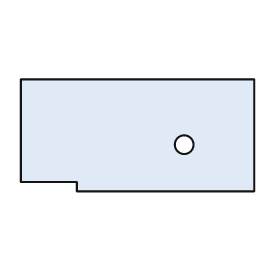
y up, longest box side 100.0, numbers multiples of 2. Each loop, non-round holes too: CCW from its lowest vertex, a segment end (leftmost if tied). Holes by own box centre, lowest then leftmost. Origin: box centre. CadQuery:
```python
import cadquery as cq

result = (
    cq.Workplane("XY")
    .moveTo(-26.0, -24.0)
    .lineTo(50.0, -24.0)
    .lineTo(50.0, 24.0)
    .lineTo(-50.0, 24.0)
    .lineTo(-50.0, -20.0)
    .lineTo(-26.0, -20.0)
    .close()
    .moveTo(20.0, -4.0)
    .circle(4.0)
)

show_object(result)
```